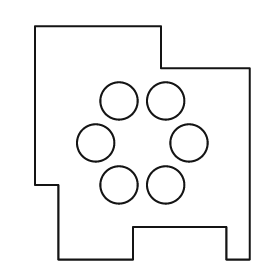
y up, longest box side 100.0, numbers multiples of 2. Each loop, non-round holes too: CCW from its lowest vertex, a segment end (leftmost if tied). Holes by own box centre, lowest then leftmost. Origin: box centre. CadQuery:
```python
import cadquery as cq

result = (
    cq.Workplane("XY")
    .moveTo(-36.0, -50.0)
    .lineTo(-4.0, -50.0)
    .lineTo(-4.0, -36.0)
    .lineTo(36.0, -36.0)
    .lineTo(36.0, -50.0)
    .lineTo(46.0, -50.0)
    .lineTo(46.0, 32.0)
    .lineTo(8.0, 32.0)
    .lineTo(8.0, 50.0)
    .lineTo(-46.0, 50.0)
    .lineTo(-46.0, -18.0)
    .lineTo(-36.0, -18.0)
    .close()
    .moveTo(-10.0, -18.0)
    .circle(8.0)
    .moveTo(10.0, -18.0)
    .circle(8.0)
    .moveTo(-20.0, 0.0)
    .circle(8.0)
    .moveTo(20.0, 0.0)
    .circle(8.0)
    .moveTo(-10.0, 18.0)
    .circle(8.0)
    .moveTo(10.0, 18.0)
    .circle(8.0)
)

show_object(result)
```